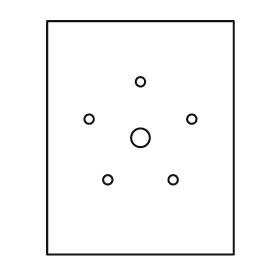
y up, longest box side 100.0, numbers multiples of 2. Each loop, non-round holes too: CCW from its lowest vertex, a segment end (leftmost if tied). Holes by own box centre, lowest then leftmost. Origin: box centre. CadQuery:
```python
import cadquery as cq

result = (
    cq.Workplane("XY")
    .moveTo(-40.0, -50.0)
    .lineTo(40.0, -50.0)
    .lineTo(40.0, 50.0)
    .lineTo(-40.0, 50.0)
    .close()
    .moveTo(-14.0, -18.0)
    .circle(2.0)
    .moveTo(14.0, -18.0)
    .circle(2.0)
    .moveTo(0.0, 0.0)
    .circle(4.0)
    .moveTo(-22.0, 8.0)
    .circle(2.0)
    .moveTo(22.0, 8.0)
    .circle(2.0)
    .moveTo(0.0, 24.0)
    .circle(2.0)
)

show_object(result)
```